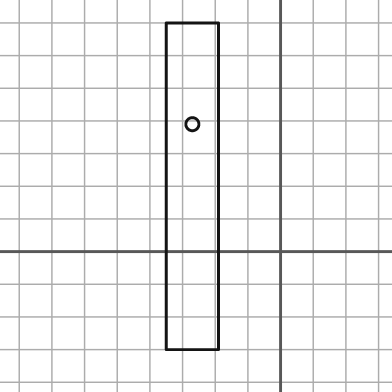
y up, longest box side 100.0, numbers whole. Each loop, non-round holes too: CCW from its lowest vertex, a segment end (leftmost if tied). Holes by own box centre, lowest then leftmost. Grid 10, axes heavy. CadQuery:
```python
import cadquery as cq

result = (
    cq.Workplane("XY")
    .moveTo(-35.0, -30.0)
    .lineTo(-19.0, -30.0)
    .lineTo(-19.0, 70.0)
    .lineTo(-35.0, 70.0)
    .close()
    .moveTo(-27.0, 39.0)
    .circle(2.0)
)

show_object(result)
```